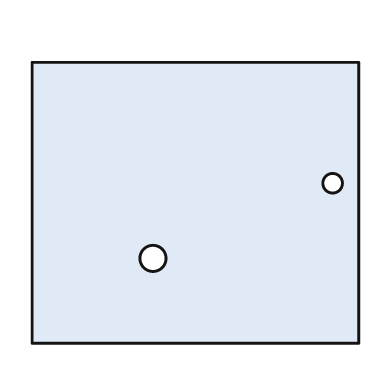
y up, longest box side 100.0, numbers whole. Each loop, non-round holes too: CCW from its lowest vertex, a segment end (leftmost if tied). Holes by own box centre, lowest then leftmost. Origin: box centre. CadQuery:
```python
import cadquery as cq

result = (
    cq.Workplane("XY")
    .moveTo(-50.0, -43.0)
    .lineTo(50.0, -43.0)
    .lineTo(50.0, 43.0)
    .lineTo(-50.0, 43.0)
    .close()
    .moveTo(-13.0, -17.0)
    .circle(4.0)
    .moveTo(42.0, 6.0)
    .circle(3.0)
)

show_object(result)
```